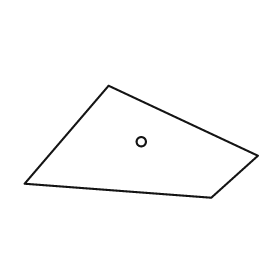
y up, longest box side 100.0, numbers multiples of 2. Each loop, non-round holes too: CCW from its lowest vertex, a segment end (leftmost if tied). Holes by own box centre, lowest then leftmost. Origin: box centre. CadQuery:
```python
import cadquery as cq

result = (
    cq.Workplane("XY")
    .moveTo(30.0, -24.0)
    .lineTo(50.0, -6.0)
    .lineTo(-14.0, 24.0)
    .lineTo(-50.0, -18.0)
    .close()
    .moveTo(0.0, 0.0)
    .circle(2.0)
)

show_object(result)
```